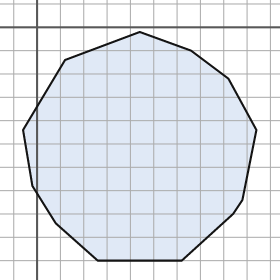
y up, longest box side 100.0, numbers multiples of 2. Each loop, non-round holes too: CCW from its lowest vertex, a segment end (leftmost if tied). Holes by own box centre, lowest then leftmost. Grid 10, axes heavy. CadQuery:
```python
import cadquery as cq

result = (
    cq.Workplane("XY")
    .moveTo(26.0, -100.0)
    .lineTo(62.0, -100.0)
    .lineTo(84.0, -80.0)
    .lineTo(88.0, -74.0)
    .lineTo(94.0, -44.0)
    .lineTo(82.0, -22.0)
    .lineTo(66.0, -10.0)
    .lineTo(44.0, -2.0)
    .lineTo(12.0, -14.0)
    .lineTo(-6.0, -44.0)
    .lineTo(-2.0, -68.0)
    .lineTo(8.0, -84.0)
    .close()
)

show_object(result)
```